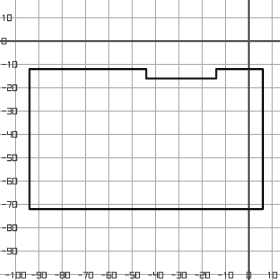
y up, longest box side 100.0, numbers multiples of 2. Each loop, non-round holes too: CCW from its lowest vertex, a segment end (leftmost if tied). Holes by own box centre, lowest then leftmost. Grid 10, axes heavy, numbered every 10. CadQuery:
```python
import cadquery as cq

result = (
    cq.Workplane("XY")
    .moveTo(-94.0, -72.0)
    .lineTo(6.0, -72.0)
    .lineTo(6.0, -12.0)
    .lineTo(-14.0, -12.0)
    .lineTo(-14.0, -16.0)
    .lineTo(-44.0, -16.0)
    .lineTo(-44.0, -12.0)
    .lineTo(-94.0, -12.0)
    .close()
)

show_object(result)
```